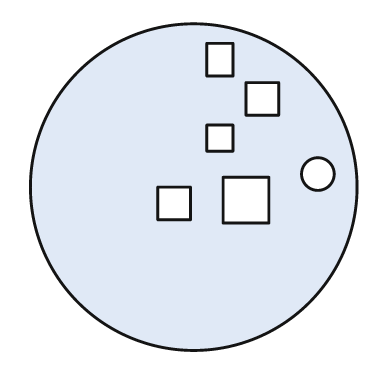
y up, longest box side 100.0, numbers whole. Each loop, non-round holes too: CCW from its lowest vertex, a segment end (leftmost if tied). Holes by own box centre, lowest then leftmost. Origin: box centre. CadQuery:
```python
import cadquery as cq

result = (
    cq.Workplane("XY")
    .moveTo(0.0, 0.0)
    .circle(50.0)
    .moveTo(-11.0, -10.0)
    .lineTo(-1.0, -10.0)
    .lineTo(-1.0, 0.0)
    .lineTo(-11.0, 0.0)
    .close()
    .moveTo(9.0, -11.0)
    .lineTo(23.0, -11.0)
    .lineTo(23.0, 3.0)
    .lineTo(9.0, 3.0)
    .close()
    .moveTo(38.0, 4.0)
    .circle(5.0)
    .moveTo(4.0, 11.0)
    .lineTo(12.0, 11.0)
    .lineTo(12.0, 19.0)
    .lineTo(4.0, 19.0)
    .close()
    .moveTo(16.0, 22.0)
    .lineTo(26.0, 22.0)
    .lineTo(26.0, 32.0)
    .lineTo(16.0, 32.0)
    .close()
    .moveTo(4.0, 34.0)
    .lineTo(12.0, 34.0)
    .lineTo(12.0, 44.0)
    .lineTo(4.0, 44.0)
    .close()
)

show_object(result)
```